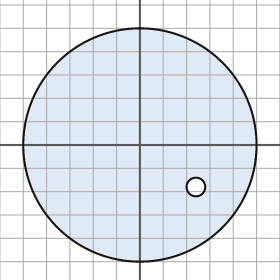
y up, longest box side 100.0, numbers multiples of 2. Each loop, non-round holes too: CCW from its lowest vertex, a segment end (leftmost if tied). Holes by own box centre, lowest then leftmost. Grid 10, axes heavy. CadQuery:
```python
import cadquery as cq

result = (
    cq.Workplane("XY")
    .moveTo(0.0, 0.0)
    .circle(50.0)
    .moveTo(24.0, -18.0)
    .circle(4.0)
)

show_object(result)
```